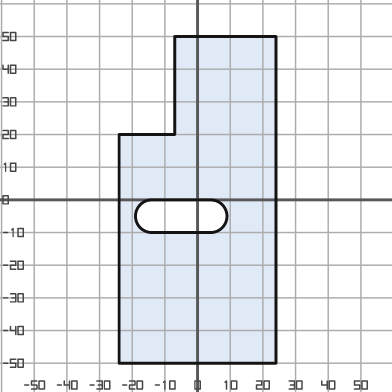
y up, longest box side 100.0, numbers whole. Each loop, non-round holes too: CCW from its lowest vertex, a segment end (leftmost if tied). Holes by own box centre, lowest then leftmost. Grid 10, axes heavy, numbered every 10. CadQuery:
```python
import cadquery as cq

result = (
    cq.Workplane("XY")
    .moveTo(-24.0, -50.0)
    .lineTo(24.0, -50.0)
    .lineTo(24.0, 50.0)
    .lineTo(-7.0, 50.0)
    .lineTo(-7.0, 20.0)
    .lineTo(-24.0, 20.0)
    .close()
    .moveTo(-14.0, -10.0)
    .lineTo(4.0, -10.0)
    .threePointArc((9.0, -5.0), (4.0, 0.0))
    .lineTo(-14.0, 0.0)
    .threePointArc((-19.0, -5.0), (-14.0, -10.0))
    .close()
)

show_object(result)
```